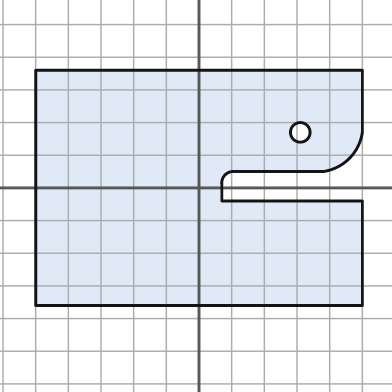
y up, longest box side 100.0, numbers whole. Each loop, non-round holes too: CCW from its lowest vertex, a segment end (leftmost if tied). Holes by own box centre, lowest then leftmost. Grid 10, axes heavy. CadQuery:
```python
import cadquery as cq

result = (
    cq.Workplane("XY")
    .moveTo(-50.0, -36.0)
    .lineTo(50.0, -36.0)
    .lineTo(50.0, -4.0)
    .lineTo(7.0, -4.0)
    .lineTo(7.0, 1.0)
    .threePointArc((8.0, 4.0), (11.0, 5.0))
    .lineTo(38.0, 5.0)
    .threePointArc((46.0, 9.0), (50.0, 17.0))
    .lineTo(50.0, 36.0)
    .lineTo(-50.0, 36.0)
    .close()
    .moveTo(31.0, 17.0)
    .circle(3.0)
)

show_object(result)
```